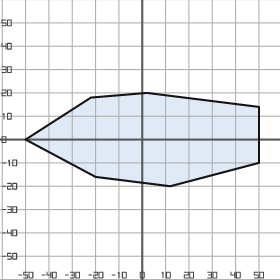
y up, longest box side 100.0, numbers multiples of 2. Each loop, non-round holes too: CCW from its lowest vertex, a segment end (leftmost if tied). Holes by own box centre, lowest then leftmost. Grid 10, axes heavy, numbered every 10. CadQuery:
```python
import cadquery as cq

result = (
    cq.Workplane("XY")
    .moveTo(12.0, -20.0)
    .lineTo(50.0, -10.0)
    .lineTo(50.0, 14.0)
    .lineTo(2.0, 20.0)
    .lineTo(-22.0, 18.0)
    .lineTo(-50.0, 0.0)
    .lineTo(-20.0, -16.0)
    .close()
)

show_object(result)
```